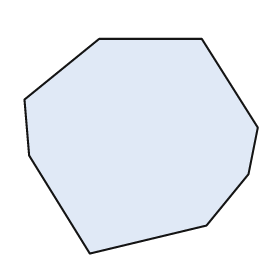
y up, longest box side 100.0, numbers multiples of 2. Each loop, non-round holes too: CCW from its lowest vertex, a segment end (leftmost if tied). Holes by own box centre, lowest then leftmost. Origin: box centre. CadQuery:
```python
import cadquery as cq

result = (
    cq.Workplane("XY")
    .moveTo(-22.0, -46.0)
    .lineTo(28.0, -34.0)
    .lineTo(46.0, -12.0)
    .lineTo(50.0, 8.0)
    .lineTo(26.0, 46.0)
    .lineTo(-18.0, 46.0)
    .lineTo(-50.0, 20.0)
    .lineTo(-48.0, -4.0)
    .close()
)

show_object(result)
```